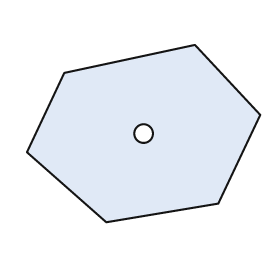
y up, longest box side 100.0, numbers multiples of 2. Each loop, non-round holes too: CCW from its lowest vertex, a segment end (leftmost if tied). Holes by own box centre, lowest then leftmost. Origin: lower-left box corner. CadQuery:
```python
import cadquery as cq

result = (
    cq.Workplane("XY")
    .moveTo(34.0, 0.0)
    .lineTo(82.0, 8.0)
    .lineTo(100.0, 46.0)
    .lineTo(72.0, 76.0)
    .lineTo(16.0, 64.0)
    .lineTo(0.0, 30.0)
    .close()
    .moveTo(50.0, 38.0)
    .circle(4.0)
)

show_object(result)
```